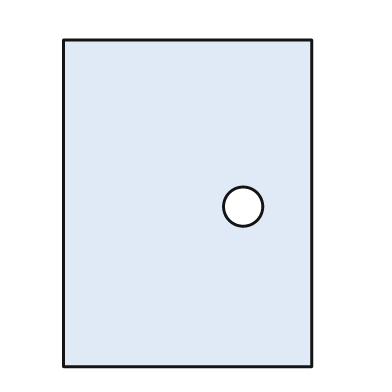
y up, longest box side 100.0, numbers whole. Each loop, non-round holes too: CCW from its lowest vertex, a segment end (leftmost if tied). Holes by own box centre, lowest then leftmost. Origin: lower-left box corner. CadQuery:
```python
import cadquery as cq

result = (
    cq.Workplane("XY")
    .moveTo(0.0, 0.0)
    .lineTo(76.0, 0.0)
    .lineTo(76.0, 100.0)
    .lineTo(0.0, 100.0)
    .close()
    .moveTo(55.0, 49.0)
    .circle(6.0)
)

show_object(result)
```